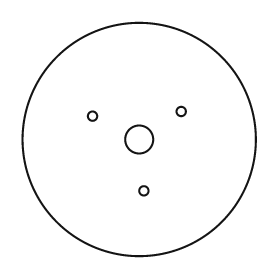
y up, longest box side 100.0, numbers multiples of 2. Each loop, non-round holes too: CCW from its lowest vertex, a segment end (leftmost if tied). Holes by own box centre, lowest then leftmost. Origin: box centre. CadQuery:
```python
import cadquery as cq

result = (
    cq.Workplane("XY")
    .moveTo(0.0, 0.0)
    .circle(50.0)
    .moveTo(2.0, -22.0)
    .circle(2.0)
    .moveTo(0.0, 0.0)
    .circle(6.0)
    .moveTo(-20.0, 10.0)
    .circle(2.0)
    .moveTo(18.0, 12.0)
    .circle(2.0)
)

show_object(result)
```